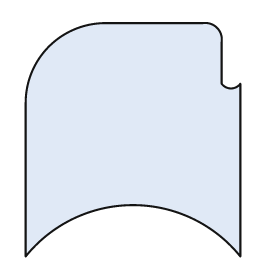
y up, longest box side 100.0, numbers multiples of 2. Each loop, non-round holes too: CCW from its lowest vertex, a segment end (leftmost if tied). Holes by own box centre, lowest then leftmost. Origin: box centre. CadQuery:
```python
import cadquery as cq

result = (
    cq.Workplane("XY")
    .moveTo(-46.0, -50.0)
    .threePointArc((0.0, -28.0), (46.0, -50.0))
    .lineTo(46.0, 24.0)
    .threePointArc((42.0, 22.0), (38.0, 24.0))
    .lineTo(38.0, 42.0)
    .threePointArc((36.0, 48.0), (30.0, 50.0))
    .lineTo(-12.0, 50.0)
    .threePointArc((-36.0, 40.0), (-46.0, 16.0))
    .close()
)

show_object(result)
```